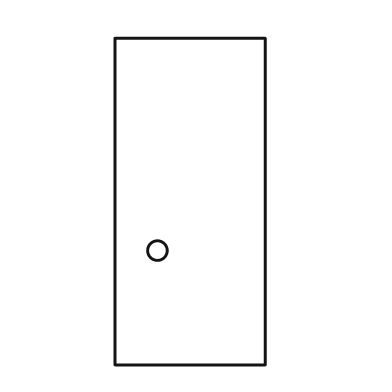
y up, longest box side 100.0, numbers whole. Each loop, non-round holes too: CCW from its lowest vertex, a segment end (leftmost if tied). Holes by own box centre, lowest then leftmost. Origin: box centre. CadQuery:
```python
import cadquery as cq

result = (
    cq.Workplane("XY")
    .moveTo(-23.0, -50.0)
    .lineTo(23.0, -50.0)
    .lineTo(23.0, 50.0)
    .lineTo(-23.0, 50.0)
    .close()
    .moveTo(-10.0, -15.0)
    .circle(3.0)
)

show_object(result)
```